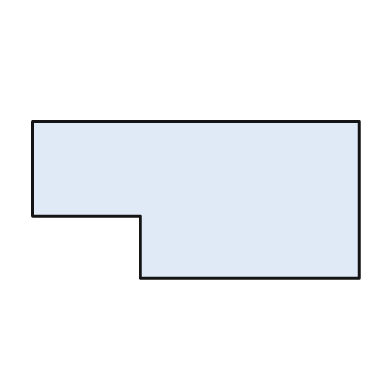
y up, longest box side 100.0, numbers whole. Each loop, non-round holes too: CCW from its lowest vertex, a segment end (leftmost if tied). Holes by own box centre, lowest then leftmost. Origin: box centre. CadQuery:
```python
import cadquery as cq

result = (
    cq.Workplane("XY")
    .moveTo(-17.0, -24.0)
    .lineTo(50.0, -24.0)
    .lineTo(50.0, 24.0)
    .lineTo(-50.0, 24.0)
    .lineTo(-50.0, -5.0)
    .lineTo(-17.0, -5.0)
    .close()
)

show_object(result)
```